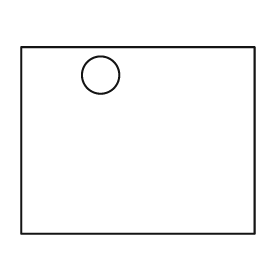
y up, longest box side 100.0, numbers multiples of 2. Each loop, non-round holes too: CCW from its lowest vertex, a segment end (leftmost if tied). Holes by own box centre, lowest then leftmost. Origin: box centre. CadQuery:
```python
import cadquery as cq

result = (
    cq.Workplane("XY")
    .moveTo(-50.0, -40.0)
    .lineTo(50.0, -40.0)
    .lineTo(50.0, 40.0)
    .lineTo(-50.0, 40.0)
    .close()
    .moveTo(-16.0, 28.0)
    .circle(8.0)
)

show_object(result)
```